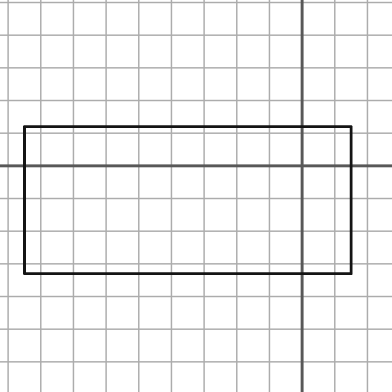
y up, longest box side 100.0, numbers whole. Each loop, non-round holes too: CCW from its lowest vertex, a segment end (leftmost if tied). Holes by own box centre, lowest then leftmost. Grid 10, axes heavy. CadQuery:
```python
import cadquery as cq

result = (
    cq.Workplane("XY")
    .moveTo(-85.0, -33.0)
    .lineTo(15.0, -33.0)
    .lineTo(15.0, 12.0)
    .lineTo(-85.0, 12.0)
    .close()
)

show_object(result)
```